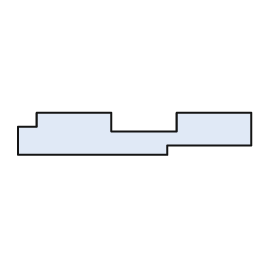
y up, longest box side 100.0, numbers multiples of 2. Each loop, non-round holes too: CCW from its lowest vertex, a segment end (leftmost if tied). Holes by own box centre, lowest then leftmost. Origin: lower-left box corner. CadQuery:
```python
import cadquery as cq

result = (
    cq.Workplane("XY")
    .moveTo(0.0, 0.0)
    .lineTo(64.0, 0.0)
    .lineTo(64.0, 4.0)
    .lineTo(100.0, 4.0)
    .lineTo(100.0, 18.0)
    .lineTo(68.0, 18.0)
    .lineTo(68.0, 10.0)
    .lineTo(40.0, 10.0)
    .lineTo(40.0, 18.0)
    .lineTo(8.0, 18.0)
    .lineTo(8.0, 12.0)
    .lineTo(0.0, 12.0)
    .close()
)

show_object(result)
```